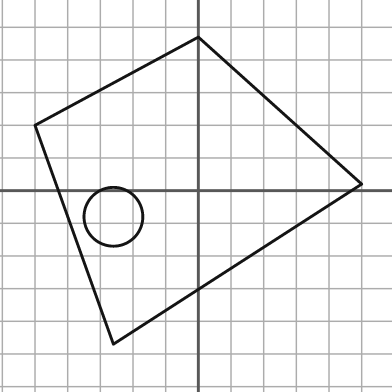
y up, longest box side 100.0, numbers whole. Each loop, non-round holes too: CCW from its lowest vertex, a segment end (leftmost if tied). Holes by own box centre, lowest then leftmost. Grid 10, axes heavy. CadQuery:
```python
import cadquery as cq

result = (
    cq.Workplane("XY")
    .moveTo(-26.0, -47.0)
    .lineTo(50.0, 2.0)
    .lineTo(0.0, 47.0)
    .lineTo(-50.0, 20.0)
    .close()
    .moveTo(-26.0, -8.0)
    .circle(9.0)
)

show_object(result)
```